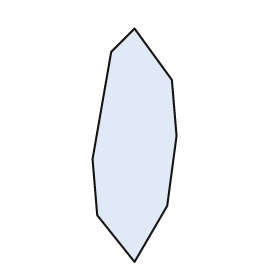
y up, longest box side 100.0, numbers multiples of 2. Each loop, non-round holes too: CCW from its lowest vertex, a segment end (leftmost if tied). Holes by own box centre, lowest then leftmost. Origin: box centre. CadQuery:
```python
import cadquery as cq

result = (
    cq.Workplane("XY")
    .moveTo(0.0, -50.0)
    .lineTo(14.0, -26.0)
    .lineTo(18.0, 4.0)
    .lineTo(16.0, 28.0)
    .lineTo(0.0, 50.0)
    .lineTo(-10.0, 40.0)
    .lineTo(-18.0, -6.0)
    .lineTo(-16.0, -30.0)
    .close()
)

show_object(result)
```